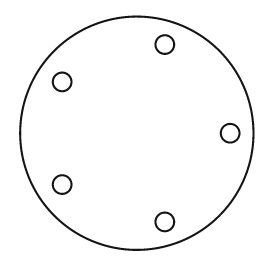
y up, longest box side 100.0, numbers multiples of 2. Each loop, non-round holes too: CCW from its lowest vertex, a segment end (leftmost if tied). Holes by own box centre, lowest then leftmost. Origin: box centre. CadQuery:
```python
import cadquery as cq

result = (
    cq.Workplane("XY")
    .moveTo(0.0, 0.0)
    .circle(50.0)
    .moveTo(12.0, -38.0)
    .circle(4.0)
    .moveTo(-32.0, -22.0)
    .circle(4.0)
    .moveTo(40.0, 0.0)
    .circle(4.0)
    .moveTo(-32.0, 22.0)
    .circle(4.0)
    .moveTo(12.0, 38.0)
    .circle(4.0)
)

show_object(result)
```